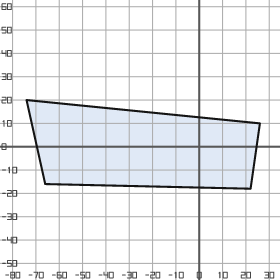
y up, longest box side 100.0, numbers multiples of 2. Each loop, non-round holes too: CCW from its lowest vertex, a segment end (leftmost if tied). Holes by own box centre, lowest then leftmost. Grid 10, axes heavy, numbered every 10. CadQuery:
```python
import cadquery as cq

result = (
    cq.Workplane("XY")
    .moveTo(22.0, -18.0)
    .lineTo(26.0, 10.0)
    .lineTo(-74.0, 20.0)
    .lineTo(-66.0, -16.0)
    .close()
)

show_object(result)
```